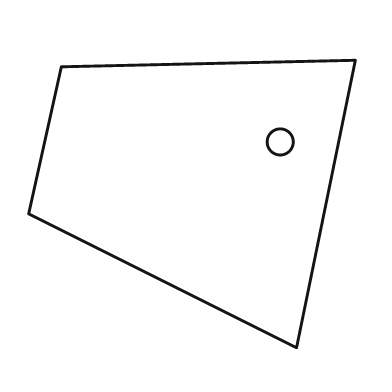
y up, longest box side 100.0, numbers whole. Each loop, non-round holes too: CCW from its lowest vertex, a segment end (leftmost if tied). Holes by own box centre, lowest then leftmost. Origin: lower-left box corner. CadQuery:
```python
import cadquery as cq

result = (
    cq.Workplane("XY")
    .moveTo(82.0, 0.0)
    .lineTo(100.0, 88.0)
    .lineTo(10.0, 86.0)
    .lineTo(0.0, 41.0)
    .close()
    .moveTo(77.0, 63.0)
    .circle(4.0)
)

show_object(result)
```